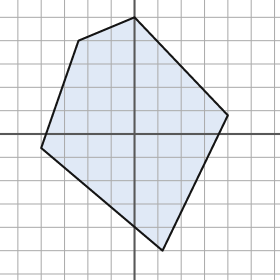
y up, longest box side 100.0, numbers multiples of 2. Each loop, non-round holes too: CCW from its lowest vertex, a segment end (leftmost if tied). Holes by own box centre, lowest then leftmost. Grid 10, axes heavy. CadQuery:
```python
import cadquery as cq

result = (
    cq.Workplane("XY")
    .moveTo(12.0, -50.0)
    .lineTo(40.0, 8.0)
    .lineTo(0.0, 50.0)
    .lineTo(-24.0, 40.0)
    .lineTo(-40.0, -6.0)
    .close()
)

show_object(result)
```